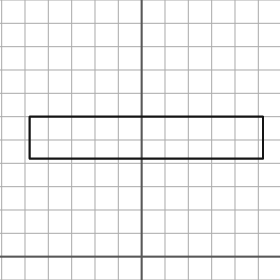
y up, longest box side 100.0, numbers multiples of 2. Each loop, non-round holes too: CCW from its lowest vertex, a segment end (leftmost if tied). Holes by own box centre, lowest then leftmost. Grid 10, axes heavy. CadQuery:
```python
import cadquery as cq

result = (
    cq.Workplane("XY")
    .moveTo(-48.0, 42.0)
    .lineTo(52.0, 42.0)
    .lineTo(52.0, 60.0)
    .lineTo(-48.0, 60.0)
    .close()
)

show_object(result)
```